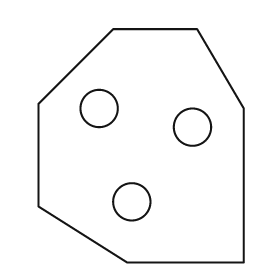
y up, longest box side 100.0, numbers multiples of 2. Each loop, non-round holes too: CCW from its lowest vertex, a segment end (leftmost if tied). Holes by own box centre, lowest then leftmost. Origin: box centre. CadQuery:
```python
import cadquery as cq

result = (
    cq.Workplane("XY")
    .moveTo(-6.0, -50.0)
    .lineTo(44.0, -50.0)
    .lineTo(44.0, 16.0)
    .lineTo(24.0, 50.0)
    .lineTo(-12.0, 50.0)
    .lineTo(-44.0, 18.0)
    .lineTo(-44.0, -26.0)
    .close()
    .moveTo(-4.0, -24.0)
    .circle(8.0)
    .moveTo(22.0, 8.0)
    .circle(8.0)
    .moveTo(-18.0, 16.0)
    .circle(8.0)
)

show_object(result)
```